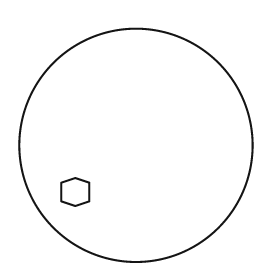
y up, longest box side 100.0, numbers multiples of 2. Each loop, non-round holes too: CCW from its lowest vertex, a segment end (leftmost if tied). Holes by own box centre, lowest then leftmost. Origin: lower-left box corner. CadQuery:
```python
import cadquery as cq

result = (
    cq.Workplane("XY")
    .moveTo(50.0, 50.0)
    .circle(50.0)
    .moveTo(24.0, 24.0)
    .lineTo(30.0, 26.0)
    .lineTo(30.0, 34.0)
    .lineTo(24.0, 36.0)
    .lineTo(18.0, 34.0)
    .lineTo(18.0, 26.0)
    .close()
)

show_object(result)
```